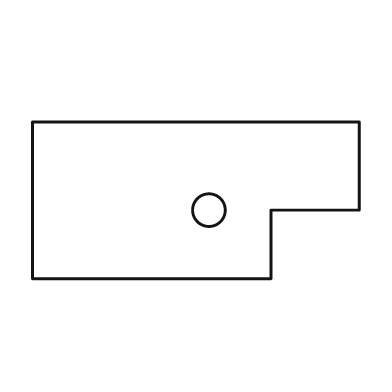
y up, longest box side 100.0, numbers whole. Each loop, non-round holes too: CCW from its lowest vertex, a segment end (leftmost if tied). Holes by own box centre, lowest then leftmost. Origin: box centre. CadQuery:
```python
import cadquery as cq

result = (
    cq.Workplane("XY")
    .moveTo(-50.0, -24.0)
    .lineTo(23.0, -24.0)
    .lineTo(23.0, -3.0)
    .lineTo(50.0, -3.0)
    .lineTo(50.0, 24.0)
    .lineTo(-50.0, 24.0)
    .close()
    .moveTo(4.0, -3.0)
    .circle(5.0)
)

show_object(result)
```